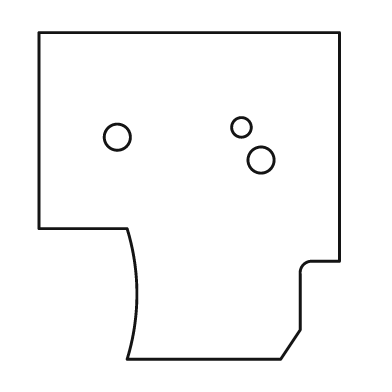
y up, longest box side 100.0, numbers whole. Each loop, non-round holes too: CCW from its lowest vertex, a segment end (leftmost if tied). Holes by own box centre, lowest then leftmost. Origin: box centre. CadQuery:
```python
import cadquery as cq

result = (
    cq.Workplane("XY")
    .moveTo(-19.0, -50.0)
    .lineTo(28.0, -50.0)
    .lineTo(34.0, -41.0)
    .lineTo(34.0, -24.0)
    .threePointArc((35.0, -21.0), (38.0, -20.0))
    .lineTo(46.0, -20.0)
    .lineTo(46.0, 50.0)
    .lineTo(-46.0, 50.0)
    .lineTo(-46.0, -10.0)
    .lineTo(-19.0, -10.0)
    .threePointArc((-16.0, -30.0), (-19.0, -50.0))
    .close()
    .moveTo(22.0, 11.0)
    .circle(4.0)
    .moveTo(-22.0, 18.0)
    .circle(4.0)
    .moveTo(16.0, 21.0)
    .circle(3.0)
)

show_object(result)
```